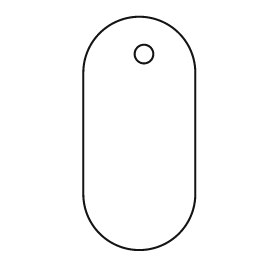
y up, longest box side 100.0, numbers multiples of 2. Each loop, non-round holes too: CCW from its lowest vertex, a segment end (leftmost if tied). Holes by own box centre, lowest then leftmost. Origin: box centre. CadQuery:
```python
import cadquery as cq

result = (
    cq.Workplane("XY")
    .moveTo(-24.0, -26.0)
    .threePointArc((0.0, -50.0), (24.0, -26.0))
    .lineTo(24.0, 26.0)
    .threePointArc((0.0, 50.0), (-24.0, 26.0))
    .close()
    .moveTo(2.0, 34.0)
    .circle(4.0)
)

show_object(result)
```